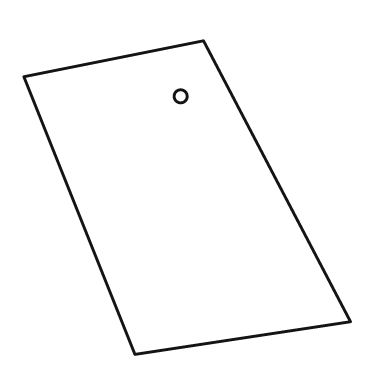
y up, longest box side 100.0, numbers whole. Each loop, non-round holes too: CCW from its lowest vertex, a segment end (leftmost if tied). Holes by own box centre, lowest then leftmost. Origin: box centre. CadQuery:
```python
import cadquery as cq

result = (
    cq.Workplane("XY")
    .moveTo(-16.0, -48.0)
    .lineTo(50.0, -38.0)
    .lineTo(5.0, 48.0)
    .lineTo(-50.0, 37.0)
    .close()
    .moveTo(-2.0, 31.0)
    .circle(2.0)
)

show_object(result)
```